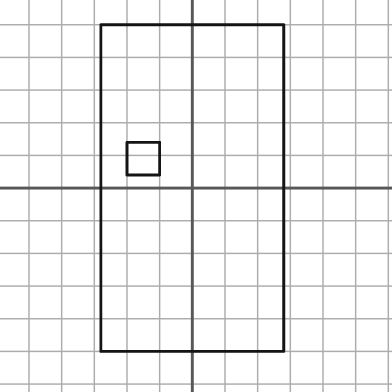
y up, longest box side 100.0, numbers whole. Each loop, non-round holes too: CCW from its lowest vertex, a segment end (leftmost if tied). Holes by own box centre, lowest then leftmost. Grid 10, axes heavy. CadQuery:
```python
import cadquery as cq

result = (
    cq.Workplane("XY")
    .moveTo(-28.0, -50.0)
    .lineTo(28.0, -50.0)
    .lineTo(28.0, 50.0)
    .lineTo(-28.0, 50.0)
    .close()
    .moveTo(-20.0, 4.0)
    .lineTo(-10.0, 4.0)
    .lineTo(-10.0, 14.0)
    .lineTo(-20.0, 14.0)
    .close()
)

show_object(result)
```